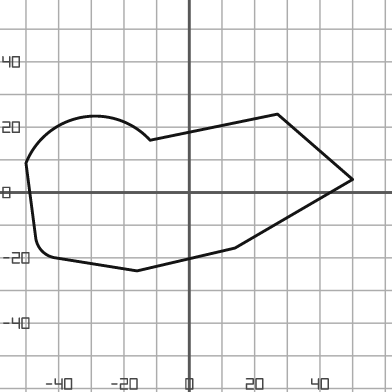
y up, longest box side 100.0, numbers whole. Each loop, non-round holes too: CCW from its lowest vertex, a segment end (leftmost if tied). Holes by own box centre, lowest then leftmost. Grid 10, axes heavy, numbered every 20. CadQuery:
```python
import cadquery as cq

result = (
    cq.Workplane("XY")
    .moveTo(-16.0, -24.0)
    .lineTo(14.0, -17.0)
    .lineTo(50.0, 4.0)
    .lineTo(27.0, 24.0)
    .lineTo(-12.0, 16.0)
    .threePointArc((-33.0, 23.0), (-50.0, 9.0))
    .lineTo(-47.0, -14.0)
    .threePointArc((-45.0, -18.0), (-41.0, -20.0))
    .close()
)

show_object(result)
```